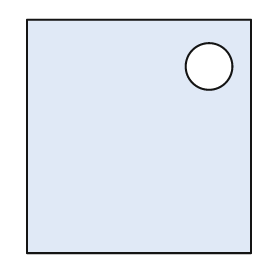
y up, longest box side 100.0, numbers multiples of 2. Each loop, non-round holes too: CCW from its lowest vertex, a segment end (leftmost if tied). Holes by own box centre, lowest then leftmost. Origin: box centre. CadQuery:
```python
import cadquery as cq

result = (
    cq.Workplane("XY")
    .moveTo(-48.0, -50.0)
    .lineTo(48.0, -50.0)
    .lineTo(48.0, 50.0)
    .lineTo(-48.0, 50.0)
    .close()
    .moveTo(30.0, 30.0)
    .circle(10.0)
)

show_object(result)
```